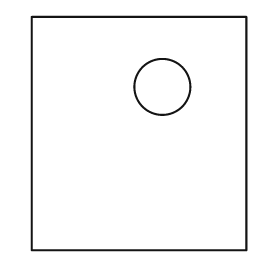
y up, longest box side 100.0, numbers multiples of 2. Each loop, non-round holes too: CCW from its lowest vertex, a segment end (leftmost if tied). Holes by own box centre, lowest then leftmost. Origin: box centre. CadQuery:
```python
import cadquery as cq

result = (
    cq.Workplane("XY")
    .moveTo(-46.0, -50.0)
    .lineTo(46.0, -50.0)
    .lineTo(46.0, 50.0)
    .lineTo(-46.0, 50.0)
    .close()
    .moveTo(10.0, 20.0)
    .circle(12.0)
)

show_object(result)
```